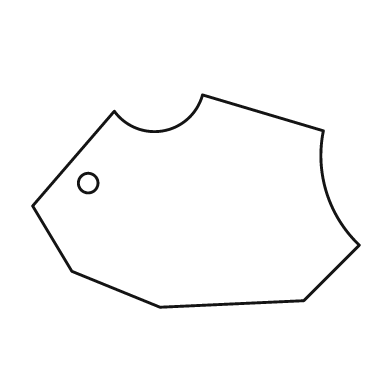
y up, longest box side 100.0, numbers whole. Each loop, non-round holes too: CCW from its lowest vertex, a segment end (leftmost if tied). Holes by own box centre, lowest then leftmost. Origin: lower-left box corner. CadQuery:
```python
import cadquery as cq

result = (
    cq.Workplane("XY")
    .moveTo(39.0, 0.0)
    .lineTo(83.0, 2.0)
    .lineTo(100.0, 19.0)
    .threePointArc((90.0, 35.0), (89.0, 54.0))
    .lineTo(52.0, 65.0)
    .threePointArc((40.0, 54.0), (25.0, 60.0))
    .lineTo(0.0, 31.0)
    .lineTo(12.0, 11.0)
    .close()
    .moveTo(17.0, 38.0)
    .circle(3.0)
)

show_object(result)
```